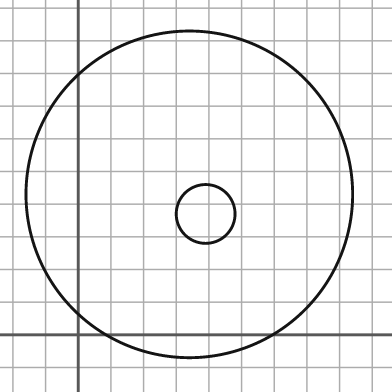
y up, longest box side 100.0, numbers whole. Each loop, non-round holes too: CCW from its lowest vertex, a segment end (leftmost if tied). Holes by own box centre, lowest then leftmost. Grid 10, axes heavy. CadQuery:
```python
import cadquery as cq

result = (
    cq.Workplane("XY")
    .moveTo(34.0, 43.0)
    .circle(50.0)
    .moveTo(39.0, 37.0)
    .circle(9.0)
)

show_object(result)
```